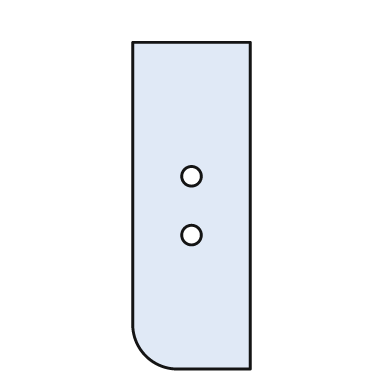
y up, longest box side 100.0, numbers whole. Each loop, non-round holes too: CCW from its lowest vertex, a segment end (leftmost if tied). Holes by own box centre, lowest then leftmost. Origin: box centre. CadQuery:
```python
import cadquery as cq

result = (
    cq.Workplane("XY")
    .moveTo(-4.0, -50.0)
    .lineTo(18.0, -50.0)
    .lineTo(18.0, 50.0)
    .lineTo(-18.0, 50.0)
    .lineTo(-18.0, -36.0)
    .threePointArc((-14.0, -46.0), (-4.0, -50.0))
    .close()
    .moveTo(0.0, -9.0)
    .circle(3.0)
    .moveTo(0.0, 9.0)
    .circle(3.0)
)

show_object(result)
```